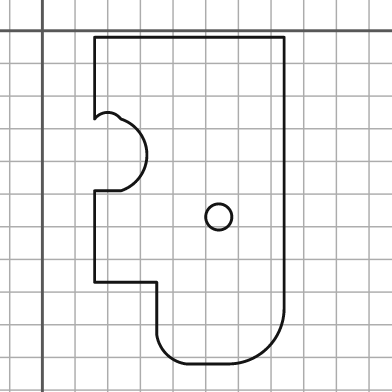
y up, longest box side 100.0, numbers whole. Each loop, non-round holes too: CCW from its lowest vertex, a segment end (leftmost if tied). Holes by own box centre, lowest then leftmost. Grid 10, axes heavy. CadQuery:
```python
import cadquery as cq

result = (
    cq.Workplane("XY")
    .moveTo(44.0, -102.0)
    .lineTo(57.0, -102.0)
    .threePointArc((69.0, -97.0), (74.0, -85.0))
    .lineTo(74.0, -2.0)
    .lineTo(16.0, -2.0)
    .lineTo(16.0, -27.0)
    .threePointArc((20.0, -25.0), (24.0, -27.0))
    .threePointArc((32.0, -38.0), (24.0, -49.0))
    .lineTo(16.0, -49.0)
    .lineTo(16.0, -77.0)
    .lineTo(35.0, -77.0)
    .lineTo(35.0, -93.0)
    .threePointArc((38.0, -99.0), (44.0, -102.0))
    .close()
    .moveTo(54.0, -57.0)
    .circle(4.0)
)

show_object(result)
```